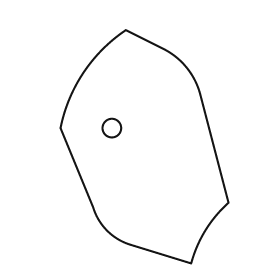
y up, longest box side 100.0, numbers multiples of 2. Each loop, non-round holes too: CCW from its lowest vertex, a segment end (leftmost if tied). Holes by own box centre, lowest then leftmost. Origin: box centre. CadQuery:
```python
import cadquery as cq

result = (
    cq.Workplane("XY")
    .moveTo(20.0, -50.0)
    .threePointArc((26.0, -36.0), (36.0, -24.0))
    .lineTo(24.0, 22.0)
    .threePointArc((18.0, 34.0), (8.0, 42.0))
    .lineTo(-8.0, 50.0)
    .threePointArc((-26.0, 32.0), (-36.0, 8.0))
    .lineTo(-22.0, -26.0)
    .threePointArc((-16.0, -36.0), (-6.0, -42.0))
    .close()
    .moveTo(-14.0, 8.0)
    .circle(4.0)
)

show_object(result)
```